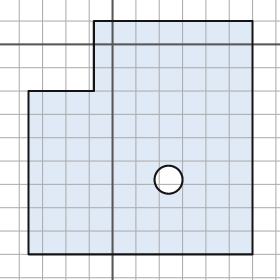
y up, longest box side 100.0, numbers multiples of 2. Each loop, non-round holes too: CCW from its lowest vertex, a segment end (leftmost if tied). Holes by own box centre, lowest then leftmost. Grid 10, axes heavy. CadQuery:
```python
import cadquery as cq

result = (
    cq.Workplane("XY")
    .moveTo(-36.0, -90.0)
    .lineTo(60.0, -90.0)
    .lineTo(60.0, 10.0)
    .lineTo(-8.0, 10.0)
    .lineTo(-8.0, -20.0)
    .lineTo(-36.0, -20.0)
    .close()
    .moveTo(24.0, -58.0)
    .circle(6.0)
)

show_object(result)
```